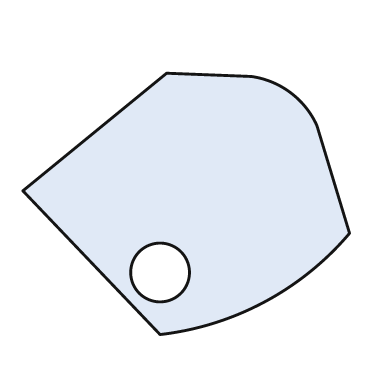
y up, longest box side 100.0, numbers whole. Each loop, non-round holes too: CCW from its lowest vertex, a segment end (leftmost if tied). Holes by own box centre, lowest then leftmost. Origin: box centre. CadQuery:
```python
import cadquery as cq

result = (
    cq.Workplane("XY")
    .moveTo(-8.0, -40.0)
    .threePointArc((24.0, -30.0), (50.0, -9.0))
    .lineTo(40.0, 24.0)
    .threePointArc((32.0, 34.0), (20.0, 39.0))
    .lineTo(-6.0, 40.0)
    .lineTo(-50.0, 4.0)
    .close()
    .moveTo(-8.0, -21.0)
    .circle(9.0)
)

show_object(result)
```